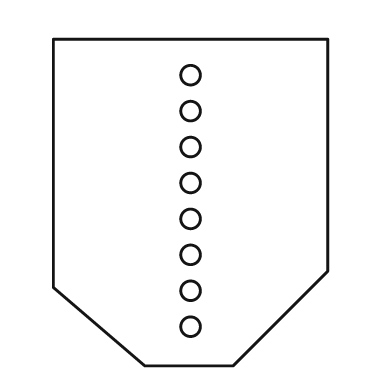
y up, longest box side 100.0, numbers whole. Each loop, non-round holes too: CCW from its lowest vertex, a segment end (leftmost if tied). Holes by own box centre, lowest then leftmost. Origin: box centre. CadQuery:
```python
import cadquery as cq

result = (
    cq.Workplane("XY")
    .moveTo(-14.0, -50.0)
    .lineTo(13.0, -50.0)
    .lineTo(42.0, -21.0)
    .lineTo(42.0, 50.0)
    .lineTo(-42.0, 50.0)
    .lineTo(-42.0, -26.0)
    .close()
    .moveTo(0.0, -38.0)
    .circle(3.0)
    .moveTo(0.0, -27.0)
    .circle(3.0)
    .moveTo(0.0, -16.0)
    .circle(3.0)
    .moveTo(0.0, -5.0)
    .circle(3.0)
    .moveTo(0.0, 6.0)
    .circle(3.0)
    .moveTo(0.0, 17.0)
    .circle(3.0)
    .moveTo(0.0, 28.0)
    .circle(3.0)
    .moveTo(0.0, 39.0)
    .circle(3.0)
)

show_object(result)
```